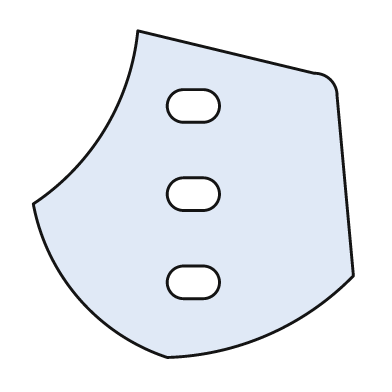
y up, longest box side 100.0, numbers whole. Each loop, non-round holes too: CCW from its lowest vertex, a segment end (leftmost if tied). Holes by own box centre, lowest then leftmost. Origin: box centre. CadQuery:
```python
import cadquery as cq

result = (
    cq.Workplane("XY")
    .moveTo(-8.0, -50.0)
    .threePointArc((23.0, -43.0), (49.0, -25.0))
    .lineTo(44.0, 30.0)
    .threePointArc((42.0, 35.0), (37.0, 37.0))
    .lineTo(-17.0, 50.0)
    .threePointArc((-27.0, 20.0), (-49.0, -3.0))
    .threePointArc((-35.0, -32.0), (-8.0, -50.0))
    .close()
    .moveTo(-3.0, -32.0)
    .lineTo(3.0, -32.0)
    .threePointArc((8.0, -27.0), (3.0, -22.0))
    .lineTo(-3.0, -22.0)
    .threePointArc((-8.0, -27.0), (-3.0, -32.0))
    .close()
    .moveTo(-3.0, -5.0)
    .lineTo(3.0, -5.0)
    .threePointArc((8.0, 0.0), (3.0, 5.0))
    .lineTo(-3.0, 5.0)
    .threePointArc((-8.0, 0.0), (-3.0, -5.0))
    .close()
    .moveTo(-3.0, 22.0)
    .lineTo(3.0, 22.0)
    .threePointArc((8.0, 27.0), (3.0, 32.0))
    .lineTo(-3.0, 32.0)
    .threePointArc((-8.0, 27.0), (-3.0, 22.0))
    .close()
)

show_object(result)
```